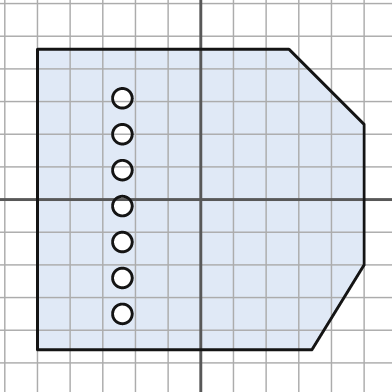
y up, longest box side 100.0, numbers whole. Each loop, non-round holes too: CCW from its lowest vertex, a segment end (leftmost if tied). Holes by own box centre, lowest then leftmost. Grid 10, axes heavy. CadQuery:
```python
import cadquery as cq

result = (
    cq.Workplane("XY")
    .moveTo(-50.0, -46.0)
    .lineTo(34.0, -46.0)
    .lineTo(50.0, -20.0)
    .lineTo(50.0, 23.0)
    .lineTo(27.0, 46.0)
    .lineTo(-50.0, 46.0)
    .close()
    .moveTo(-24.0, -35.0)
    .circle(3.0)
    .moveTo(-24.0, -24.0)
    .circle(3.0)
    .moveTo(-24.0, -13.0)
    .circle(3.0)
    .moveTo(-24.0, -2.0)
    .circle(3.0)
    .moveTo(-24.0, 9.0)
    .circle(3.0)
    .moveTo(-24.0, 20.0)
    .circle(3.0)
    .moveTo(-24.0, 31.0)
    .circle(3.0)
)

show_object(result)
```